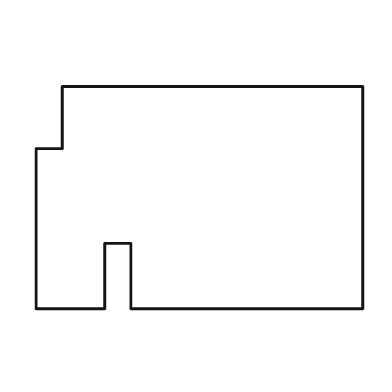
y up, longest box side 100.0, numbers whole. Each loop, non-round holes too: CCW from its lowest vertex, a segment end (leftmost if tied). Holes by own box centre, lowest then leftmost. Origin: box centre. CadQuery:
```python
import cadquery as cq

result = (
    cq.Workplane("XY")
    .moveTo(-50.0, -34.0)
    .lineTo(-29.0, -34.0)
    .lineTo(-29.0, -14.0)
    .lineTo(-21.0, -14.0)
    .lineTo(-21.0, -34.0)
    .lineTo(50.0, -34.0)
    .lineTo(50.0, 34.0)
    .lineTo(-42.0, 34.0)
    .lineTo(-42.0, 15.0)
    .lineTo(-50.0, 15.0)
    .close()
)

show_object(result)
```